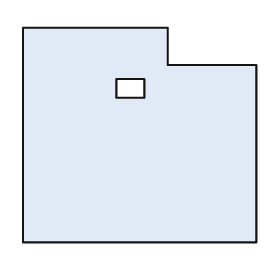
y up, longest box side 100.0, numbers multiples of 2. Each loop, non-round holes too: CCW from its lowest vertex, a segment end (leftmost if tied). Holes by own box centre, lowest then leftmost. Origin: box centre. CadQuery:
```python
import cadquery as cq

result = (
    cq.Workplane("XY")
    .moveTo(-50.0, -46.0)
    .lineTo(50.0, -46.0)
    .lineTo(50.0, 30.0)
    .lineTo(12.0, 30.0)
    .lineTo(12.0, 46.0)
    .lineTo(-50.0, 46.0)
    .close()
    .moveTo(-10.0, 16.0)
    .lineTo(2.0, 16.0)
    .lineTo(2.0, 24.0)
    .lineTo(-10.0, 24.0)
    .close()
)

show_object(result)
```